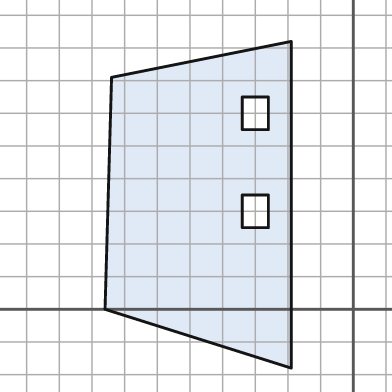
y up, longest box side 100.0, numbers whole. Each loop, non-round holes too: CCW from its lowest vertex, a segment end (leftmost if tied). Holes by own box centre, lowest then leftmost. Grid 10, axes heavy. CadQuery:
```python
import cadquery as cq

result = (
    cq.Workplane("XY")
    .moveTo(-19.0, -18.0)
    .lineTo(-19.0, 82.0)
    .lineTo(-74.0, 71.0)
    .lineTo(-76.0, 0.0)
    .close()
    .moveTo(-34.0, 25.0)
    .lineTo(-26.0, 25.0)
    .lineTo(-26.0, 35.0)
    .lineTo(-34.0, 35.0)
    .close()
    .moveTo(-34.0, 55.0)
    .lineTo(-26.0, 55.0)
    .lineTo(-26.0, 65.0)
    .lineTo(-34.0, 65.0)
    .close()
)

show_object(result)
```